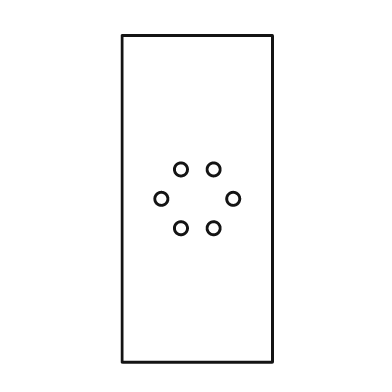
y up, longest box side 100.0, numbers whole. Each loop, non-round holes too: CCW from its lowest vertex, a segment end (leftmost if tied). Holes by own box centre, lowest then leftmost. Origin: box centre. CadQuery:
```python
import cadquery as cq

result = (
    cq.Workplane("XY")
    .moveTo(-23.0, -50.0)
    .lineTo(23.0, -50.0)
    .lineTo(23.0, 50.0)
    .lineTo(-23.0, 50.0)
    .close()
    .moveTo(-5.0, -9.0)
    .circle(2.0)
    .moveTo(5.0, -9.0)
    .circle(2.0)
    .moveTo(-11.0, 0.0)
    .circle(2.0)
    .moveTo(11.0, 0.0)
    .circle(2.0)
    .moveTo(-5.0, 9.0)
    .circle(2.0)
    .moveTo(5.0, 9.0)
    .circle(2.0)
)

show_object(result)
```